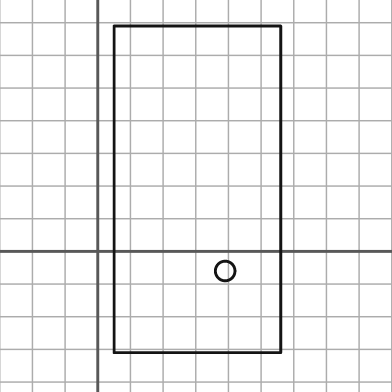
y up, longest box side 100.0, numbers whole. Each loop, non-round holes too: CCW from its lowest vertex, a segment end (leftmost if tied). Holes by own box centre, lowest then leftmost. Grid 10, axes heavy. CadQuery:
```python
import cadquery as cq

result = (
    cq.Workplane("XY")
    .moveTo(5.0, -31.0)
    .lineTo(56.0, -31.0)
    .lineTo(56.0, 69.0)
    .lineTo(5.0, 69.0)
    .close()
    .moveTo(39.0, -6.0)
    .circle(3.0)
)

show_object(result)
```